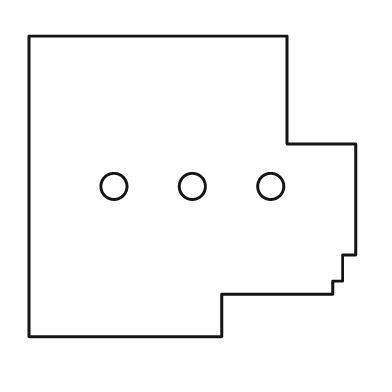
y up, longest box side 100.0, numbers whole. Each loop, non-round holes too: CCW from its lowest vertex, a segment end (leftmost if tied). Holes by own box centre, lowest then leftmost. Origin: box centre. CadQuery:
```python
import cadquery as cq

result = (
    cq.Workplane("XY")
    .moveTo(-50.0, -46.0)
    .lineTo(9.0, -46.0)
    .lineTo(9.0, -33.0)
    .lineTo(43.0, -33.0)
    .lineTo(43.0, -29.0)
    .lineTo(46.0, -29.0)
    .lineTo(46.0, -21.0)
    .lineTo(50.0, -21.0)
    .lineTo(50.0, 13.0)
    .lineTo(29.0, 13.0)
    .lineTo(29.0, 46.0)
    .lineTo(-50.0, 46.0)
    .close()
    .moveTo(-24.0, 0.0)
    .circle(4.0)
    .moveTo(0.0, 0.0)
    .circle(4.0)
    .moveTo(24.0, 0.0)
    .circle(4.0)
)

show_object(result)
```